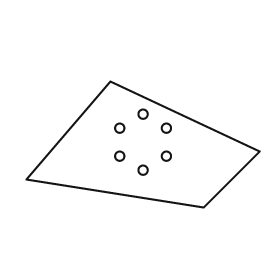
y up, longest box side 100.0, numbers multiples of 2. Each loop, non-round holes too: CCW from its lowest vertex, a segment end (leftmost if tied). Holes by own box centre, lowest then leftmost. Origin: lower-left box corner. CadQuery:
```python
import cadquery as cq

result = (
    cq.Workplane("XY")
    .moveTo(76.0, 0.0)
    .lineTo(100.0, 24.0)
    .lineTo(36.0, 54.0)
    .lineTo(0.0, 12.0)
    .close()
    .moveTo(50.0, 16.0)
    .circle(2.0)
    .moveTo(40.0, 22.0)
    .circle(2.0)
    .moveTo(60.0, 22.0)
    .circle(2.0)
    .moveTo(40.0, 34.0)
    .circle(2.0)
    .moveTo(60.0, 34.0)
    .circle(2.0)
    .moveTo(50.0, 40.0)
    .circle(2.0)
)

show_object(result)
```